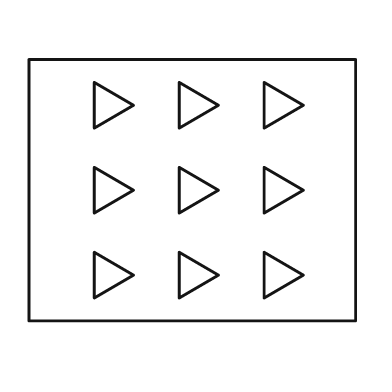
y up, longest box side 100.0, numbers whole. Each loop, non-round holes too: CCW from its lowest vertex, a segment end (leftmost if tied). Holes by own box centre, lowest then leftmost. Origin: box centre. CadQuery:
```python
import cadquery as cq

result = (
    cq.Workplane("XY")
    .moveTo(-50.0, -40.0)
    .lineTo(50.0, -40.0)
    .lineTo(50.0, 40.0)
    .lineTo(-50.0, 40.0)
    .close()
    .moveTo(-30.0, -33.0)
    .lineTo(-18.0, -26.0)
    .lineTo(-30.0, -19.0)
    .close()
    .moveTo(-4.0, -33.0)
    .lineTo(8.0, -26.0)
    .lineTo(-4.0, -19.0)
    .close()
    .moveTo(22.0, -33.0)
    .lineTo(34.0, -26.0)
    .lineTo(22.0, -19.0)
    .close()
    .moveTo(-30.0, -7.0)
    .lineTo(-18.0, 0.0)
    .lineTo(-30.0, 7.0)
    .close()
    .moveTo(-4.0, -7.0)
    .lineTo(8.0, 0.0)
    .lineTo(-4.0, 7.0)
    .close()
    .moveTo(22.0, -7.0)
    .lineTo(34.0, 0.0)
    .lineTo(22.0, 7.0)
    .close()
    .moveTo(-30.0, 19.0)
    .lineTo(-18.0, 26.0)
    .lineTo(-30.0, 33.0)
    .close()
    .moveTo(-4.0, 19.0)
    .lineTo(8.0, 26.0)
    .lineTo(-4.0, 33.0)
    .close()
    .moveTo(22.0, 19.0)
    .lineTo(34.0, 26.0)
    .lineTo(22.0, 33.0)
    .close()
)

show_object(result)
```